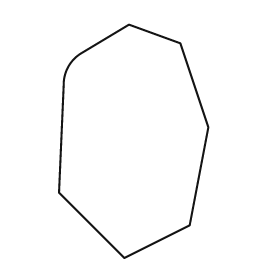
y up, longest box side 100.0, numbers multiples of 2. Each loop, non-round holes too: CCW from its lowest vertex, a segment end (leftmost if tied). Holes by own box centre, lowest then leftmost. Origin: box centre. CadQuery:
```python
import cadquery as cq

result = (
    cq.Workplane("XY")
    .moveTo(-4.0, -50.0)
    .lineTo(24.0, -36.0)
    .lineTo(32.0, 6.0)
    .lineTo(20.0, 42.0)
    .lineTo(-2.0, 50.0)
    .lineTo(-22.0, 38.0)
    .threePointArc((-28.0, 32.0), (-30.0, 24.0))
    .lineTo(-32.0, -22.0)
    .close()
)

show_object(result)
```